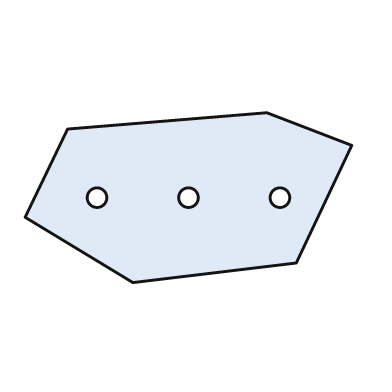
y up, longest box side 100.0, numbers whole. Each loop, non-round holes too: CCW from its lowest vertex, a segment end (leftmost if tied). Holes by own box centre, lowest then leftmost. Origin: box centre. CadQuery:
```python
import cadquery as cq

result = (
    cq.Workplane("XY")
    .moveTo(-17.0, -26.0)
    .lineTo(33.0, -20.0)
    .lineTo(50.0, 16.0)
    .lineTo(24.0, 26.0)
    .lineTo(-37.0, 21.0)
    .lineTo(-50.0, -6.0)
    .close()
    .moveTo(-28.0, 0.0)
    .circle(3.0)
    .moveTo(0.0, 0.0)
    .circle(3.0)
    .moveTo(28.0, 0.0)
    .circle(3.0)
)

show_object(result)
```